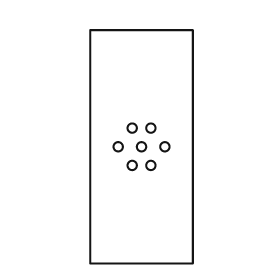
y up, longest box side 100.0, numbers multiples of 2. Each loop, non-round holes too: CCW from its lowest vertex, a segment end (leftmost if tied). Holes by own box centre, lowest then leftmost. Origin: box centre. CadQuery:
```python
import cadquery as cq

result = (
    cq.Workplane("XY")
    .moveTo(-22.0, -50.0)
    .lineTo(22.0, -50.0)
    .lineTo(22.0, 50.0)
    .lineTo(-22.0, 50.0)
    .close()
    .moveTo(-4.0, -8.0)
    .circle(2.0)
    .moveTo(4.0, -8.0)
    .circle(2.0)
    .moveTo(-10.0, 0.0)
    .circle(2.0)
    .moveTo(0.0, 0.0)
    .circle(2.0)
    .moveTo(10.0, 0.0)
    .circle(2.0)
    .moveTo(-4.0, 8.0)
    .circle(2.0)
    .moveTo(4.0, 8.0)
    .circle(2.0)
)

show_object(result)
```